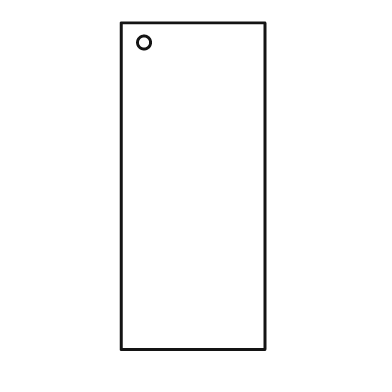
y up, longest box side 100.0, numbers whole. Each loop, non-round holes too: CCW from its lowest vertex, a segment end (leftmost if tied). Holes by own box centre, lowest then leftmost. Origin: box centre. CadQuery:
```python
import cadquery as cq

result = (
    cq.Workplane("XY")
    .moveTo(-22.0, -50.0)
    .lineTo(22.0, -50.0)
    .lineTo(22.0, 50.0)
    .lineTo(-22.0, 50.0)
    .close()
    .moveTo(-15.0, 44.0)
    .circle(2.0)
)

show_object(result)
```